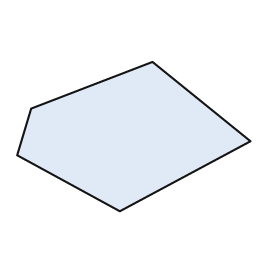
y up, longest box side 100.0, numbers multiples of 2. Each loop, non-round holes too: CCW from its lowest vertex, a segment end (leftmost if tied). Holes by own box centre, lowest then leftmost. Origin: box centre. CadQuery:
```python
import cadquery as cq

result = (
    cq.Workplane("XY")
    .moveTo(-6.0, -32.0)
    .lineTo(50.0, -2.0)
    .lineTo(8.0, 32.0)
    .lineTo(-44.0, 12.0)
    .lineTo(-50.0, -8.0)
    .close()
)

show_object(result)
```